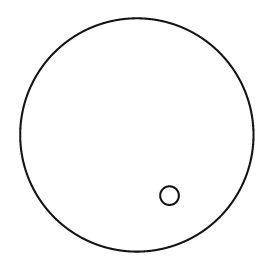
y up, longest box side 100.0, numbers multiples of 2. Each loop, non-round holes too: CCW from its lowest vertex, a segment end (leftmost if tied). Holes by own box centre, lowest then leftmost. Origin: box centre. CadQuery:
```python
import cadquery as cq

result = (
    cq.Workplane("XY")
    .moveTo(0.0, 0.0)
    .circle(50.0)
    .moveTo(14.0, -26.0)
    .circle(4.0)
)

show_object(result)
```